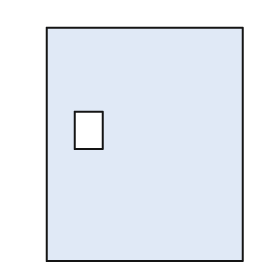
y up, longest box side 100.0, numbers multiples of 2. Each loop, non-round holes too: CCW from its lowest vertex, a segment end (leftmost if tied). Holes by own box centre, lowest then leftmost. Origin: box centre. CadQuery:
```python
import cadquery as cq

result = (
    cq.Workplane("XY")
    .moveTo(-42.0, -50.0)
    .lineTo(42.0, -50.0)
    .lineTo(42.0, 50.0)
    .lineTo(-42.0, 50.0)
    .close()
    .moveTo(-30.0, -2.0)
    .lineTo(-18.0, -2.0)
    .lineTo(-18.0, 14.0)
    .lineTo(-30.0, 14.0)
    .close()
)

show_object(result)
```